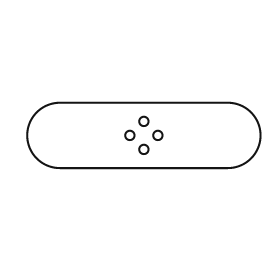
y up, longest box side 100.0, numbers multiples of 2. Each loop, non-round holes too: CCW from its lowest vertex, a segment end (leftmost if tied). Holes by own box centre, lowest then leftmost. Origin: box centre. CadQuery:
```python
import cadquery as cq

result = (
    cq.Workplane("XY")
    .moveTo(-36.0, -14.0)
    .lineTo(36.0, -14.0)
    .threePointArc((50.0, 0.0), (36.0, 14.0))
    .lineTo(-36.0, 14.0)
    .threePointArc((-50.0, 0.0), (-36.0, -14.0))
    .close()
    .moveTo(0.0, -6.0)
    .circle(2.0)
    .moveTo(-6.0, 0.0)
    .circle(2.0)
    .moveTo(6.0, 0.0)
    .circle(2.0)
    .moveTo(0.0, 6.0)
    .circle(2.0)
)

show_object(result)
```